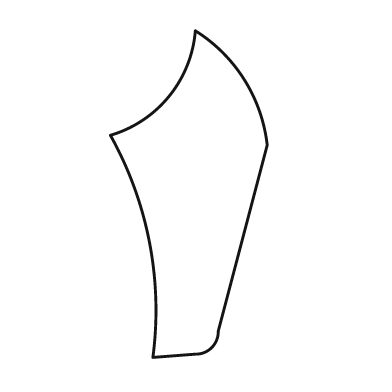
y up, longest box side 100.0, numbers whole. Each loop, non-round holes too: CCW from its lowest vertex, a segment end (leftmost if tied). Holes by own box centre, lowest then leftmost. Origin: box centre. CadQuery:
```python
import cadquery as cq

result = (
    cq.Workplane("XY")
    .moveTo(-11.0, -50.0)
    .lineTo(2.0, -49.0)
    .threePointArc((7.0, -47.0), (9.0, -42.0))
    .lineTo(24.0, 15.0)
    .threePointArc((17.0, 35.0), (2.0, 50.0))
    .threePointArc((-6.0, 30.0), (-24.0, 18.0))
    .threePointArc((-12.0, -15.0), (-11.0, -50.0))
    .close()
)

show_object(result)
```